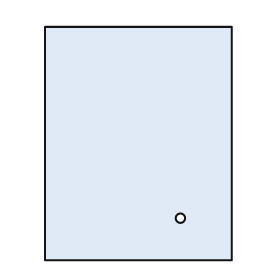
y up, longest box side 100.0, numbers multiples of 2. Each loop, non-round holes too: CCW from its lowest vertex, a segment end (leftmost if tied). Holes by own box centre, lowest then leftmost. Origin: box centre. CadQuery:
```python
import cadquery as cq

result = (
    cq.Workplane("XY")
    .moveTo(-40.0, -50.0)
    .lineTo(40.0, -50.0)
    .lineTo(40.0, 50.0)
    .lineTo(-40.0, 50.0)
    .close()
    .moveTo(18.0, -32.0)
    .circle(2.0)
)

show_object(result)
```